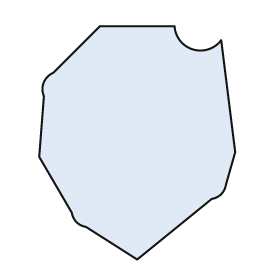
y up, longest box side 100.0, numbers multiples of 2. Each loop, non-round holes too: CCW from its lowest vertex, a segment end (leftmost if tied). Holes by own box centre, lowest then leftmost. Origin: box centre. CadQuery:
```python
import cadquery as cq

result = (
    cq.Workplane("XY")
    .moveTo(0.0, -50.0)
    .lineTo(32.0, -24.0)
    .threePointArc((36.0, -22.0), (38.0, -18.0))
    .lineTo(42.0, -4.0)
    .lineTo(36.0, 44.0)
    .threePointArc((24.0, 40.0), (16.0, 50.0))
    .lineTo(-16.0, 50.0)
    .lineTo(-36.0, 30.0)
    .threePointArc((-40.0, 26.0), (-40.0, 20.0))
    .lineTo(-42.0, -6.0)
    .lineTo(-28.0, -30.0)
    .threePointArc((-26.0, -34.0), (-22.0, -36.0))
    .close()
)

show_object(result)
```